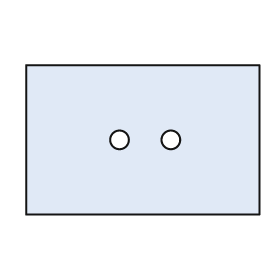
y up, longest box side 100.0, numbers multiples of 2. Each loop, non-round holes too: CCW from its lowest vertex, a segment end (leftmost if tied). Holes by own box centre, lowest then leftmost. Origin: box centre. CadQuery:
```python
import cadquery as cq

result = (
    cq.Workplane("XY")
    .moveTo(-50.0, -32.0)
    .lineTo(50.0, -32.0)
    .lineTo(50.0, 32.0)
    .lineTo(-50.0, 32.0)
    .close()
    .moveTo(-10.0, 0.0)
    .circle(4.0)
    .moveTo(12.0, 0.0)
    .circle(4.0)
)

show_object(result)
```